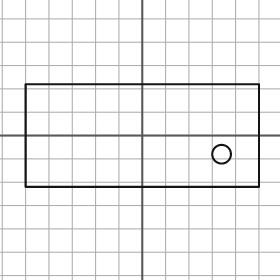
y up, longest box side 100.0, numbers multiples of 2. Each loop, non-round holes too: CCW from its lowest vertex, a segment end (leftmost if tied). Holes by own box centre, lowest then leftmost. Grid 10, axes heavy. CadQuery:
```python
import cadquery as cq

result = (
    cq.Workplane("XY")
    .moveTo(-50.0, -22.0)
    .lineTo(50.0, -22.0)
    .lineTo(50.0, 22.0)
    .lineTo(-50.0, 22.0)
    .close()
    .moveTo(34.0, -8.0)
    .circle(4.0)
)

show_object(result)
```